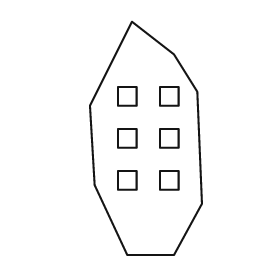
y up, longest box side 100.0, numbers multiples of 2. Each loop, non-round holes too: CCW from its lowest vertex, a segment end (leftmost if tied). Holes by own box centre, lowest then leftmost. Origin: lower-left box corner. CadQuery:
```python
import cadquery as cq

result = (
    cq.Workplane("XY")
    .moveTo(16.0, 0.0)
    .lineTo(36.0, 0.0)
    .lineTo(48.0, 22.0)
    .lineTo(46.0, 70.0)
    .lineTo(36.0, 86.0)
    .lineTo(18.0, 100.0)
    .lineTo(0.0, 64.0)
    .lineTo(2.0, 30.0)
    .close()
    .moveTo(12.0, 28.0)
    .lineTo(20.0, 28.0)
    .lineTo(20.0, 36.0)
    .lineTo(12.0, 36.0)
    .close()
    .moveTo(30.0, 28.0)
    .lineTo(38.0, 28.0)
    .lineTo(38.0, 36.0)
    .lineTo(30.0, 36.0)
    .close()
    .moveTo(12.0, 46.0)
    .lineTo(20.0, 46.0)
    .lineTo(20.0, 54.0)
    .lineTo(12.0, 54.0)
    .close()
    .moveTo(30.0, 46.0)
    .lineTo(38.0, 46.0)
    .lineTo(38.0, 54.0)
    .lineTo(30.0, 54.0)
    .close()
    .moveTo(12.0, 64.0)
    .lineTo(20.0, 64.0)
    .lineTo(20.0, 72.0)
    .lineTo(12.0, 72.0)
    .close()
    .moveTo(30.0, 64.0)
    .lineTo(38.0, 64.0)
    .lineTo(38.0, 72.0)
    .lineTo(30.0, 72.0)
    .close()
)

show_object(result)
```